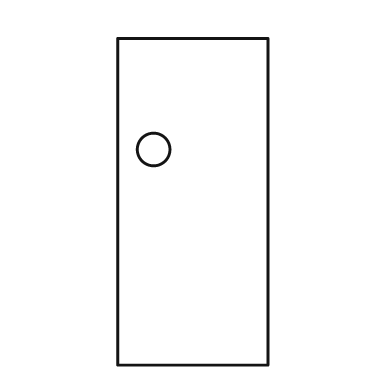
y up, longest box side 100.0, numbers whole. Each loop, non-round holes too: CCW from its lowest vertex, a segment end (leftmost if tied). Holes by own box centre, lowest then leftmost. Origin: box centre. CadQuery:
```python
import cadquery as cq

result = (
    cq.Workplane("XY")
    .moveTo(-23.0, -50.0)
    .lineTo(23.0, -50.0)
    .lineTo(23.0, 50.0)
    .lineTo(-23.0, 50.0)
    .close()
    .moveTo(-12.0, 16.0)
    .circle(5.0)
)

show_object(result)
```